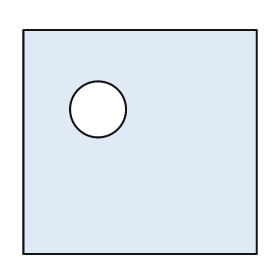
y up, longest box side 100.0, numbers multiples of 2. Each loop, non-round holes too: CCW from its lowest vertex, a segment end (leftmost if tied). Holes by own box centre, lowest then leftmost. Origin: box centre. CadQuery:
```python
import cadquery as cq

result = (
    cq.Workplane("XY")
    .moveTo(-50.0, -48.0)
    .lineTo(50.0, -48.0)
    .lineTo(50.0, 48.0)
    .lineTo(-50.0, 48.0)
    .close()
    .moveTo(-18.0, 14.0)
    .circle(12.0)
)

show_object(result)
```